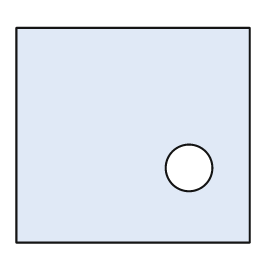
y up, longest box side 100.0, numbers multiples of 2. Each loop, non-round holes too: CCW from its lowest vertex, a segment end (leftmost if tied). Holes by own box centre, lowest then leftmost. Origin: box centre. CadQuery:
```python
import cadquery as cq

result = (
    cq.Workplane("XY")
    .moveTo(-50.0, -46.0)
    .lineTo(50.0, -46.0)
    .lineTo(50.0, 46.0)
    .lineTo(-50.0, 46.0)
    .close()
    .moveTo(24.0, -14.0)
    .circle(10.0)
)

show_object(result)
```